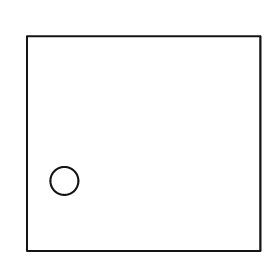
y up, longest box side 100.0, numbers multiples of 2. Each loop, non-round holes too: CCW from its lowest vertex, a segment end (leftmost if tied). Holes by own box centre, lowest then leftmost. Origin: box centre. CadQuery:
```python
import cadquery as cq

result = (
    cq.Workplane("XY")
    .moveTo(-50.0, -46.0)
    .lineTo(50.0, -46.0)
    .lineTo(50.0, 46.0)
    .lineTo(-50.0, 46.0)
    .close()
    .moveTo(-34.0, -16.0)
    .circle(6.0)
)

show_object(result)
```